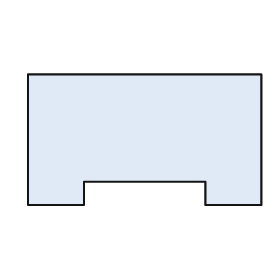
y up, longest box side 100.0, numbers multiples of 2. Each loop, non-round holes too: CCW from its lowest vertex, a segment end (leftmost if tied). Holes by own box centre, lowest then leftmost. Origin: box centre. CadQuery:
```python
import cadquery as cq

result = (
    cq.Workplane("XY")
    .moveTo(-50.0, -28.0)
    .lineTo(-26.0, -28.0)
    .lineTo(-26.0, -18.0)
    .lineTo(26.0, -18.0)
    .lineTo(26.0, -28.0)
    .lineTo(50.0, -28.0)
    .lineTo(50.0, 28.0)
    .lineTo(-50.0, 28.0)
    .close()
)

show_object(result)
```